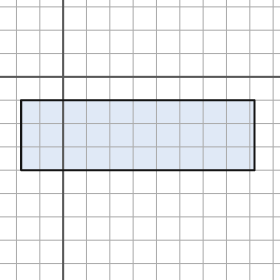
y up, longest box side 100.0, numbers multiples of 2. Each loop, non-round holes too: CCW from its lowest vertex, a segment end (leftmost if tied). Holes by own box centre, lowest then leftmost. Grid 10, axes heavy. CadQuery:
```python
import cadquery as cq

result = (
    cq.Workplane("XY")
    .moveTo(-18.0, -40.0)
    .lineTo(82.0, -40.0)
    .lineTo(82.0, -10.0)
    .lineTo(-18.0, -10.0)
    .close()
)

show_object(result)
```